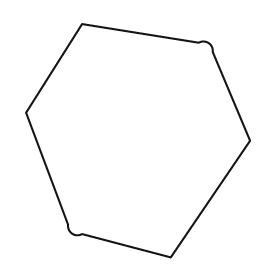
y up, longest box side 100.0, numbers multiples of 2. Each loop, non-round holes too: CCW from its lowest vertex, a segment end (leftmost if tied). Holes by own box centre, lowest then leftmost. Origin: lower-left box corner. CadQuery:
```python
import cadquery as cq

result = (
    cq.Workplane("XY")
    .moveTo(62.0, 0.0)
    .lineTo(96.0, 50.0)
    .lineTo(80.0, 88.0)
    .threePointArc((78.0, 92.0), (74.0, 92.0))
    .lineTo(24.0, 100.0)
    .lineTo(0.0, 62.0)
    .lineTo(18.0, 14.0)
    .threePointArc((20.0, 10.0), (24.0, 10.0))
    .close()
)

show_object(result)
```